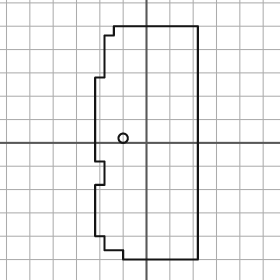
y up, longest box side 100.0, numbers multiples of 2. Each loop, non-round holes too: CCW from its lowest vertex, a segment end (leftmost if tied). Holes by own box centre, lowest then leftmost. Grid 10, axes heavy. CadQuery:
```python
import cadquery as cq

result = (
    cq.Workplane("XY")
    .moveTo(-10.0, -50.0)
    .lineTo(22.0, -50.0)
    .lineTo(22.0, 50.0)
    .lineTo(-14.0, 50.0)
    .lineTo(-14.0, 46.0)
    .lineTo(-18.0, 46.0)
    .lineTo(-18.0, 28.0)
    .lineTo(-22.0, 28.0)
    .lineTo(-22.0, -8.0)
    .lineTo(-18.0, -8.0)
    .lineTo(-18.0, -18.0)
    .lineTo(-22.0, -18.0)
    .lineTo(-22.0, -40.0)
    .lineTo(-18.0, -40.0)
    .lineTo(-18.0, -46.0)
    .lineTo(-10.0, -46.0)
    .close()
    .moveTo(-10.0, 2.0)
    .circle(2.0)
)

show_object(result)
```